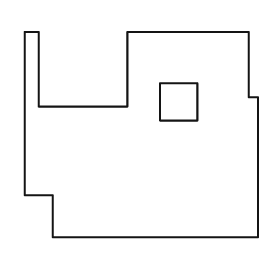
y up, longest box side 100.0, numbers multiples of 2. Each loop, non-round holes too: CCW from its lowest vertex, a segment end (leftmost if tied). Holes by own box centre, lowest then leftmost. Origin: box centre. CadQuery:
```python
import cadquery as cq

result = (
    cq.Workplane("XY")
    .moveTo(-38.0, -44.0)
    .lineTo(50.0, -44.0)
    .lineTo(50.0, 16.0)
    .lineTo(46.0, 16.0)
    .lineTo(46.0, 44.0)
    .lineTo(-6.0, 44.0)
    .lineTo(-6.0, 12.0)
    .lineTo(-44.0, 12.0)
    .lineTo(-44.0, 44.0)
    .lineTo(-50.0, 44.0)
    .lineTo(-50.0, -26.0)
    .lineTo(-38.0, -26.0)
    .close()
    .moveTo(8.0, 6.0)
    .lineTo(24.0, 6.0)
    .lineTo(24.0, 22.0)
    .lineTo(8.0, 22.0)
    .close()
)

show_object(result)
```